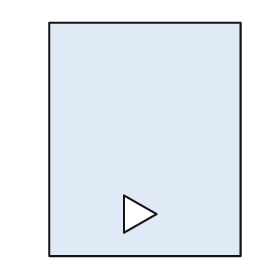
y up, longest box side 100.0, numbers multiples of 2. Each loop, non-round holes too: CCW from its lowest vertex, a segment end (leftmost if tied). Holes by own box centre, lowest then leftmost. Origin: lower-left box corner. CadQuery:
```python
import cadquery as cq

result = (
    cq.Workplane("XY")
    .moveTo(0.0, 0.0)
    .lineTo(82.0, 0.0)
    .lineTo(82.0, 100.0)
    .lineTo(0.0, 100.0)
    .close()
    .moveTo(32.0, 10.0)
    .lineTo(46.0, 18.0)
    .lineTo(32.0, 26.0)
    .close()
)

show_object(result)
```